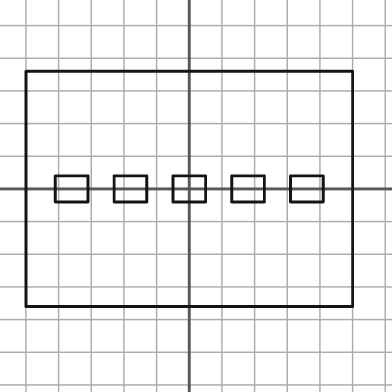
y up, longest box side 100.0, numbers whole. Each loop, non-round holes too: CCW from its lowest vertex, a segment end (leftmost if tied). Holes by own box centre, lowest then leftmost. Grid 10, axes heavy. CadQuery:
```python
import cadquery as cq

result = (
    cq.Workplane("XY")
    .moveTo(-50.0, -36.0)
    .lineTo(50.0, -36.0)
    .lineTo(50.0, 36.0)
    .lineTo(-50.0, 36.0)
    .close()
    .moveTo(-41.0, -4.0)
    .lineTo(-31.0, -4.0)
    .lineTo(-31.0, 4.0)
    .lineTo(-41.0, 4.0)
    .close()
    .moveTo(-23.0, -4.0)
    .lineTo(-13.0, -4.0)
    .lineTo(-13.0, 4.0)
    .lineTo(-23.0, 4.0)
    .close()
    .moveTo(-5.0, -4.0)
    .lineTo(5.0, -4.0)
    .lineTo(5.0, 4.0)
    .lineTo(-5.0, 4.0)
    .close()
    .moveTo(13.0, -4.0)
    .lineTo(23.0, -4.0)
    .lineTo(23.0, 4.0)
    .lineTo(13.0, 4.0)
    .close()
    .moveTo(31.0, -4.0)
    .lineTo(41.0, -4.0)
    .lineTo(41.0, 4.0)
    .lineTo(31.0, 4.0)
    .close()
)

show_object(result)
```